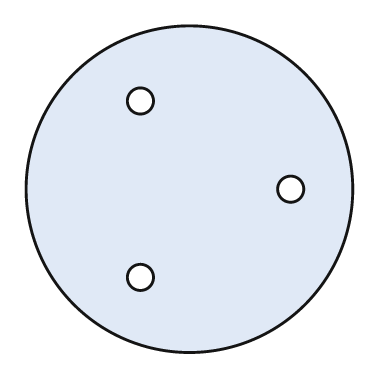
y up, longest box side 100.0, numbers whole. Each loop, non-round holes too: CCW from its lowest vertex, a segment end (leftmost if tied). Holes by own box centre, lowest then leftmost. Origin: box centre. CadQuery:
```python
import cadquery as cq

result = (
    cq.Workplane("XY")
    .moveTo(0.0, 0.0)
    .circle(50.0)
    .moveTo(-15.0, -27.0)
    .circle(4.0)
    .moveTo(31.0, 0.0)
    .circle(4.0)
    .moveTo(-15.0, 27.0)
    .circle(4.0)
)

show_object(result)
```